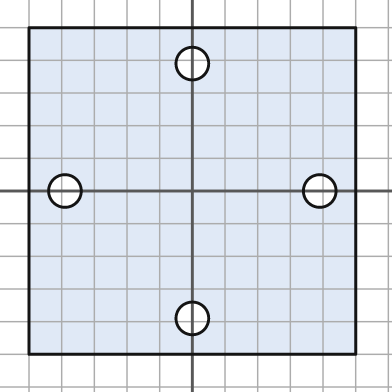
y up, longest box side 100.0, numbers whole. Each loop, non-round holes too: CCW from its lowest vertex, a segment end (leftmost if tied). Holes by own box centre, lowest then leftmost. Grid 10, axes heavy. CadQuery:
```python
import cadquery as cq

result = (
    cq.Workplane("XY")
    .moveTo(-50.0, -50.0)
    .lineTo(50.0, -50.0)
    .lineTo(50.0, 50.0)
    .lineTo(-50.0, 50.0)
    .close()
    .moveTo(0.0, -39.0)
    .circle(5.0)
    .moveTo(-39.0, 0.0)
    .circle(5.0)
    .moveTo(39.0, 0.0)
    .circle(5.0)
    .moveTo(0.0, 39.0)
    .circle(5.0)
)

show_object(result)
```